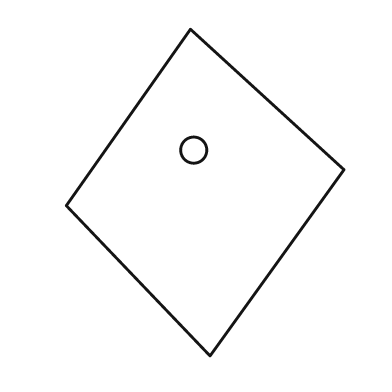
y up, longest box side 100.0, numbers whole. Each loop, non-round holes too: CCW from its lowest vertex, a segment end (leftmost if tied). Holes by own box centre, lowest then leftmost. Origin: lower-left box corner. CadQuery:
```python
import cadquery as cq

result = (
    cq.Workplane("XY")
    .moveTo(44.0, 0.0)
    .lineTo(85.0, 57.0)
    .lineTo(38.0, 100.0)
    .lineTo(0.0, 46.0)
    .close()
    .moveTo(39.0, 63.0)
    .circle(4.0)
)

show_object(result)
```